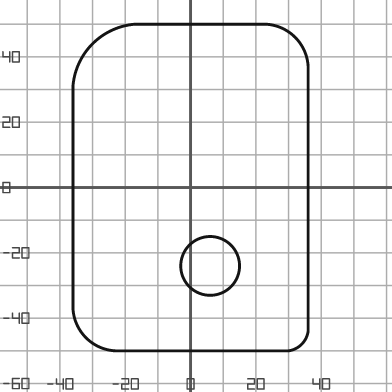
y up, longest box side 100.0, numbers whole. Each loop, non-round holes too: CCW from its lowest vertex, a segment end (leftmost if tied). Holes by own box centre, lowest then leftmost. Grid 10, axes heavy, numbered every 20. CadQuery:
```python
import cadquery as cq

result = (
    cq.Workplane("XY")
    .moveTo(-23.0, -50.0)
    .lineTo(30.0, -50.0)
    .threePointArc((34.0, -48.0), (36.0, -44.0))
    .lineTo(36.0, 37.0)
    .threePointArc((32.0, 46.0), (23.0, 50.0))
    .lineTo(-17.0, 50.0)
    .threePointArc((-30.0, 44.0), (-36.0, 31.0))
    .lineTo(-36.0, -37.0)
    .threePointArc((-32.0, -46.0), (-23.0, -50.0))
    .close()
    .moveTo(6.0, -24.0)
    .circle(9.0)
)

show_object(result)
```